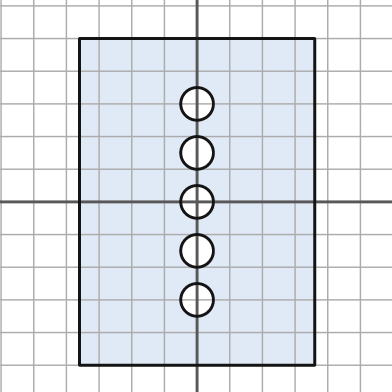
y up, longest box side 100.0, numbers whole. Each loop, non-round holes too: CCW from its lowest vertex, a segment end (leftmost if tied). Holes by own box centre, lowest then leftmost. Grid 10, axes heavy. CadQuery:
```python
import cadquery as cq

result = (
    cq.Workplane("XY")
    .moveTo(-36.0, -50.0)
    .lineTo(36.0, -50.0)
    .lineTo(36.0, 50.0)
    .lineTo(-36.0, 50.0)
    .close()
    .moveTo(0.0, -30.0)
    .circle(5.0)
    .moveTo(0.0, -15.0)
    .circle(5.0)
    .moveTo(0.0, 0.0)
    .circle(5.0)
    .moveTo(0.0, 15.0)
    .circle(5.0)
    .moveTo(0.0, 30.0)
    .circle(5.0)
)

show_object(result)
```